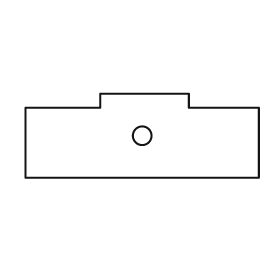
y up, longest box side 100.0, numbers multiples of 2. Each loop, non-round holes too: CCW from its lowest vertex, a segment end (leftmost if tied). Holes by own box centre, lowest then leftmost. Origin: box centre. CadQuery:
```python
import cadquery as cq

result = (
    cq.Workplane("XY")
    .moveTo(-50.0, -18.0)
    .lineTo(50.0, -18.0)
    .lineTo(50.0, 12.0)
    .lineTo(20.0, 12.0)
    .lineTo(20.0, 18.0)
    .lineTo(-18.0, 18.0)
    .lineTo(-18.0, 12.0)
    .lineTo(-50.0, 12.0)
    .close()
    .moveTo(0.0, 0.0)
    .circle(4.0)
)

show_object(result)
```